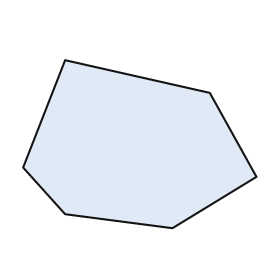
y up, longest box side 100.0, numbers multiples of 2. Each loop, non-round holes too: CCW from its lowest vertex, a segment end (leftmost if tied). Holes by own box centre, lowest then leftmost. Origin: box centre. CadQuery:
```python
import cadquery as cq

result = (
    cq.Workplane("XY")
    .moveTo(14.0, -36.0)
    .lineTo(50.0, -14.0)
    .lineTo(30.0, 22.0)
    .lineTo(-32.0, 36.0)
    .lineTo(-50.0, -10.0)
    .lineTo(-32.0, -30.0)
    .close()
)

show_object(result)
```